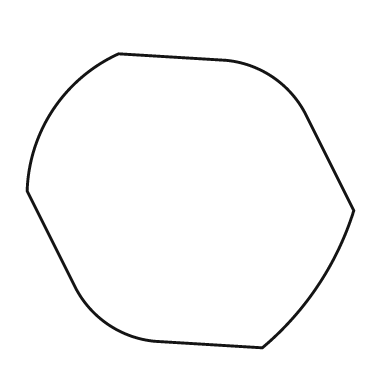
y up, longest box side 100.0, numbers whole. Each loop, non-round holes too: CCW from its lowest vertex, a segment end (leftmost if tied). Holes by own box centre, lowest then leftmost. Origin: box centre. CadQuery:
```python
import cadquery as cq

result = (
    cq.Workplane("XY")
    .moveTo(22.0, -45.0)
    .threePointArc((39.0, -26.0), (50.0, -3.0))
    .lineTo(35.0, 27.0)
    .threePointArc((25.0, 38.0), (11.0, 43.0))
    .lineTo(-22.0, 45.0)
    .threePointArc((-42.0, 28.0), (-50.0, 3.0))
    .lineTo(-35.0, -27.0)
    .threePointArc((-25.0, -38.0), (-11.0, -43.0))
    .close()
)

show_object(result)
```